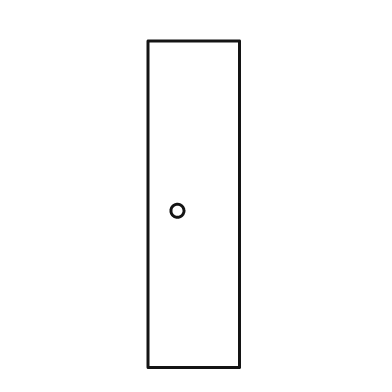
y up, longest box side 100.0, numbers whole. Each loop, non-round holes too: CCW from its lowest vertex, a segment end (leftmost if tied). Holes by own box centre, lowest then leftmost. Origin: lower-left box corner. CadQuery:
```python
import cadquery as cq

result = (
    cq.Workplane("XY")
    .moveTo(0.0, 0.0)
    .lineTo(28.0, 0.0)
    .lineTo(28.0, 100.0)
    .lineTo(0.0, 100.0)
    .close()
    .moveTo(9.0, 48.0)
    .circle(2.0)
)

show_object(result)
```